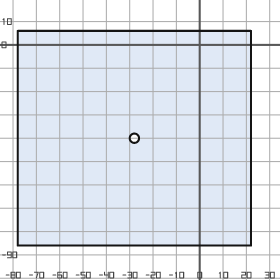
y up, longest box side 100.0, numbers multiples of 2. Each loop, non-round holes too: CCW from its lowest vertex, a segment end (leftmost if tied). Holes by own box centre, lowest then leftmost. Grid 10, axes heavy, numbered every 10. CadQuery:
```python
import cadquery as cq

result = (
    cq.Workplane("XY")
    .moveTo(-78.0, -86.0)
    .lineTo(22.0, -86.0)
    .lineTo(22.0, 6.0)
    .lineTo(-78.0, 6.0)
    .close()
    .moveTo(-28.0, -40.0)
    .circle(2.0)
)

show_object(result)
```